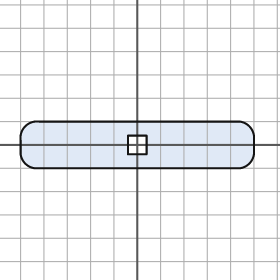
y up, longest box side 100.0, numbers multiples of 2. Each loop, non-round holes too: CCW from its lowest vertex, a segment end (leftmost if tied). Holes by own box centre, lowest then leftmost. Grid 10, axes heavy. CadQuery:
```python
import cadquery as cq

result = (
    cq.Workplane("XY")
    .moveTo(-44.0, -10.0)
    .lineTo(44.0, -10.0)
    .threePointArc((48.0, -8.0), (50.0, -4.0))
    .lineTo(50.0, 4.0)
    .threePointArc((48.0, 8.0), (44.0, 10.0))
    .lineTo(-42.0, 10.0)
    .threePointArc((-48.0, 8.0), (-50.0, 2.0))
    .lineTo(-50.0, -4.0)
    .threePointArc((-48.0, -8.0), (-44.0, -10.0))
    .close()
    .moveTo(-4.0, -4.0)
    .lineTo(4.0, -4.0)
    .lineTo(4.0, 4.0)
    .lineTo(-4.0, 4.0)
    .close()
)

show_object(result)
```